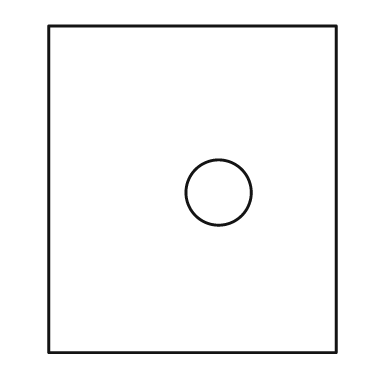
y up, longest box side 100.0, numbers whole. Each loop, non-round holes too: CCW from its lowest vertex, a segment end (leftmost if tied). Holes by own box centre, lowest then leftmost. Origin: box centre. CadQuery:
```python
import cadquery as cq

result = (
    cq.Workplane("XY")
    .moveTo(-44.0, -50.0)
    .lineTo(44.0, -50.0)
    .lineTo(44.0, 50.0)
    .lineTo(-44.0, 50.0)
    .close()
    .moveTo(8.0, -1.0)
    .circle(10.0)
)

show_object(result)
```